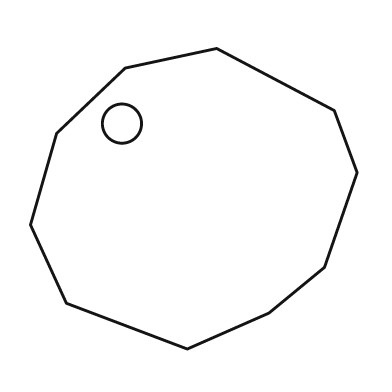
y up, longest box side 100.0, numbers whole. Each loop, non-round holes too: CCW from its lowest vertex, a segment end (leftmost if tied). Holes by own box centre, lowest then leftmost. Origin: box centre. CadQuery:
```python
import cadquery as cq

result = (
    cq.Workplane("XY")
    .moveTo(-2.0, -46.0)
    .lineTo(23.0, -35.0)
    .lineTo(40.0, -21.0)
    .lineTo(50.0, 8.0)
    .lineTo(43.0, 27.0)
    .lineTo(7.0, 46.0)
    .lineTo(-21.0, 40.0)
    .lineTo(-42.0, 20.0)
    .lineTo(-50.0, -8.0)
    .lineTo(-39.0, -32.0)
    .close()
    .moveTo(-22.0, 23.0)
    .circle(6.0)
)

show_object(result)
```